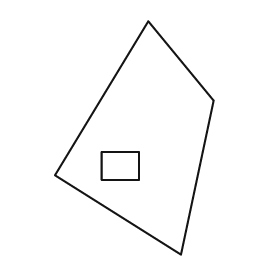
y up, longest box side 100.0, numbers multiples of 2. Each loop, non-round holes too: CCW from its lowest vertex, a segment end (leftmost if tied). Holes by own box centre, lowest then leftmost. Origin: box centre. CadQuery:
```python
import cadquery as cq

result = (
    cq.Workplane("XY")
    .moveTo(20.0, -50.0)
    .lineTo(34.0, 16.0)
    .lineTo(6.0, 50.0)
    .lineTo(-34.0, -16.0)
    .close()
    .moveTo(-14.0, -18.0)
    .lineTo(2.0, -18.0)
    .lineTo(2.0, -6.0)
    .lineTo(-14.0, -6.0)
    .close()
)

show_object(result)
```